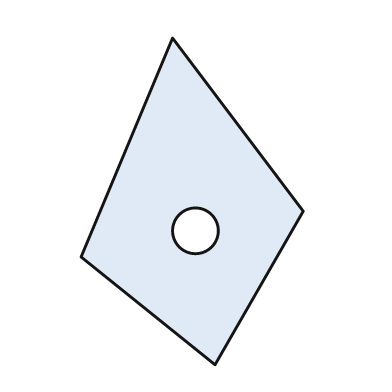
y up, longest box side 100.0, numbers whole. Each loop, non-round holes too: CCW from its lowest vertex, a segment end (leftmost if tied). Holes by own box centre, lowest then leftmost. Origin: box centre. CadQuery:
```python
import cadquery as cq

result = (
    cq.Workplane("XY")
    .moveTo(7.0, -50.0)
    .lineTo(34.0, -3.0)
    .lineTo(-6.0, 50.0)
    .lineTo(-34.0, -17.0)
    .close()
    .moveTo(1.0, -9.0)
    .circle(7.0)
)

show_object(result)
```